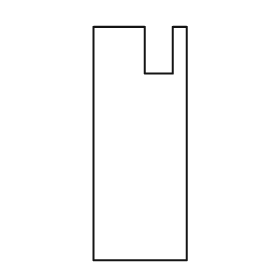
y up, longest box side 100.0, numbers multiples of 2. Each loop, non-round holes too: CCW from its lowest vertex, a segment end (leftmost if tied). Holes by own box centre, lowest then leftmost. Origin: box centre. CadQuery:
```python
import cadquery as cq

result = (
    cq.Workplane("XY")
    .moveTo(-20.0, -50.0)
    .lineTo(20.0, -50.0)
    .lineTo(20.0, 50.0)
    .lineTo(14.0, 50.0)
    .lineTo(14.0, 30.0)
    .lineTo(2.0, 30.0)
    .lineTo(2.0, 50.0)
    .lineTo(-20.0, 50.0)
    .close()
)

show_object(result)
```